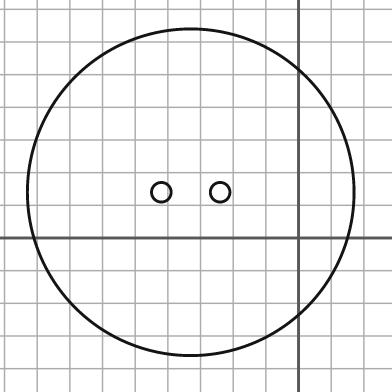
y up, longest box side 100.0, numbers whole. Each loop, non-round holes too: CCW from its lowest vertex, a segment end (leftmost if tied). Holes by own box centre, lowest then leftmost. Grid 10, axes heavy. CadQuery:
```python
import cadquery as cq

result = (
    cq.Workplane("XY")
    .moveTo(-33.0, 14.0)
    .circle(50.0)
    .moveTo(-42.0, 14.0)
    .circle(3.0)
    .moveTo(-24.0, 14.0)
    .circle(3.0)
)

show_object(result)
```